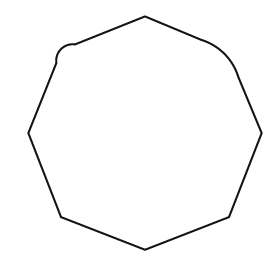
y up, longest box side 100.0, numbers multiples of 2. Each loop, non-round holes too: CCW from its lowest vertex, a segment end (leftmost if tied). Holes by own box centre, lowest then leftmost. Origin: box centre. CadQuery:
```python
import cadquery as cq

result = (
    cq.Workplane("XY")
    .moveTo(0.0, -50.0)
    .lineTo(36.0, -36.0)
    .lineTo(50.0, 0.0)
    .lineTo(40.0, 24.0)
    .threePointArc((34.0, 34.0), (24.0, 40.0))
    .lineTo(0.0, 50.0)
    .lineTo(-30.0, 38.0)
    .threePointArc((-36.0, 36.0), (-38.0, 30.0))
    .lineTo(-50.0, 0.0)
    .lineTo(-36.0, -36.0)
    .close()
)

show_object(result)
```